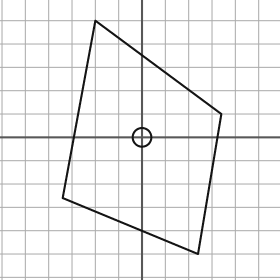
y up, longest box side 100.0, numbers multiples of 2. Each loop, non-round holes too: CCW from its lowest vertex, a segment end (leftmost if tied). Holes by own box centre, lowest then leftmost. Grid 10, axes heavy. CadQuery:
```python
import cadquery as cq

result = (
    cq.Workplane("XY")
    .moveTo(24.0, -50.0)
    .lineTo(34.0, 10.0)
    .lineTo(-20.0, 50.0)
    .lineTo(-34.0, -26.0)
    .close()
    .moveTo(0.0, 0.0)
    .circle(4.0)
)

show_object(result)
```